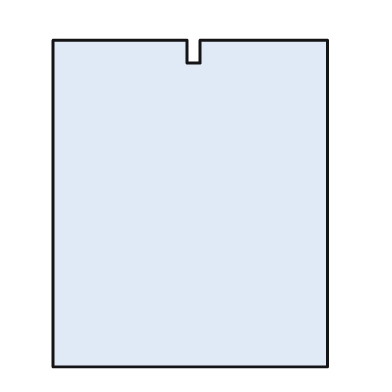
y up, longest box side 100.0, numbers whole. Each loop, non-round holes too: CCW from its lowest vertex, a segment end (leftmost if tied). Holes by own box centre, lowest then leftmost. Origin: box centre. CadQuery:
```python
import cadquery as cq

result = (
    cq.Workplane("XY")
    .moveTo(-42.0, -50.0)
    .lineTo(42.0, -50.0)
    .lineTo(42.0, 50.0)
    .lineTo(3.0, 50.0)
    .lineTo(3.0, 43.0)
    .lineTo(-1.0, 43.0)
    .lineTo(-1.0, 50.0)
    .lineTo(-42.0, 50.0)
    .close()
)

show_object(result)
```